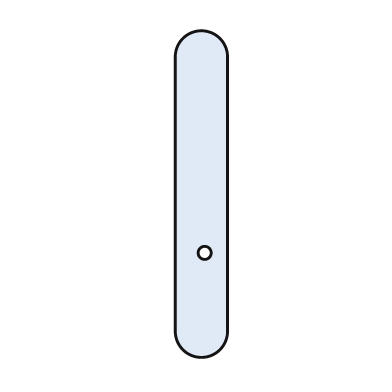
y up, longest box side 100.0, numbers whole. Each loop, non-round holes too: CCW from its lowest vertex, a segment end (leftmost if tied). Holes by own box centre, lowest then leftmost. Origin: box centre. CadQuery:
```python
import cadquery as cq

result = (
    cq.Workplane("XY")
    .moveTo(-8.0, -42.0)
    .threePointArc((0.0, -50.0), (8.0, -42.0))
    .lineTo(8.0, 42.0)
    .threePointArc((0.0, 50.0), (-8.0, 42.0))
    .close()
    .moveTo(1.0, -18.0)
    .circle(2.0)
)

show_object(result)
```